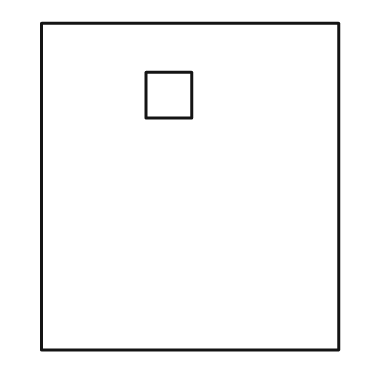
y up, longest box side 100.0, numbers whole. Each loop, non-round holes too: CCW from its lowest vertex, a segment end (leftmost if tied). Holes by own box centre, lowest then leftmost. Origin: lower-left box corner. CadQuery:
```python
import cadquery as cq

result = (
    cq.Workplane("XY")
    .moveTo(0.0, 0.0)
    .lineTo(91.0, 0.0)
    .lineTo(91.0, 100.0)
    .lineTo(0.0, 100.0)
    .close()
    .moveTo(32.0, 71.0)
    .lineTo(46.0, 71.0)
    .lineTo(46.0, 85.0)
    .lineTo(32.0, 85.0)
    .close()
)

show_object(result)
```